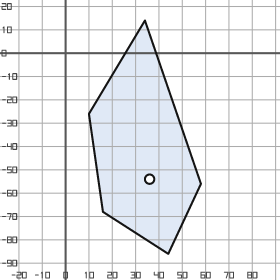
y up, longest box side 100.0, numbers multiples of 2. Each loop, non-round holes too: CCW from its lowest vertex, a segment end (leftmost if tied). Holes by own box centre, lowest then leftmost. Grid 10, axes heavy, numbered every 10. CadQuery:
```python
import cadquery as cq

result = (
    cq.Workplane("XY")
    .moveTo(44.0, -86.0)
    .lineTo(58.0, -56.0)
    .lineTo(34.0, 14.0)
    .lineTo(10.0, -26.0)
    .lineTo(16.0, -68.0)
    .close()
    .moveTo(36.0, -54.0)
    .circle(2.0)
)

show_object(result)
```